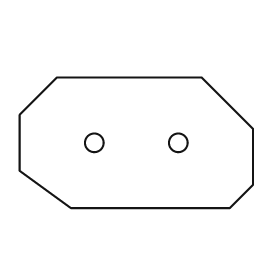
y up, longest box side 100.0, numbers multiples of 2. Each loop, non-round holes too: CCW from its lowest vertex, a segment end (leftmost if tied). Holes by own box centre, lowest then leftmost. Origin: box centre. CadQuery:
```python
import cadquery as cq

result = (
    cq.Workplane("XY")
    .moveTo(-28.0, -28.0)
    .lineTo(40.0, -28.0)
    .lineTo(50.0, -18.0)
    .lineTo(50.0, 6.0)
    .lineTo(28.0, 28.0)
    .lineTo(-34.0, 28.0)
    .lineTo(-50.0, 12.0)
    .lineTo(-50.0, -12.0)
    .close()
    .moveTo(-18.0, 0.0)
    .circle(4.0)
    .moveTo(18.0, 0.0)
    .circle(4.0)
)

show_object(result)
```